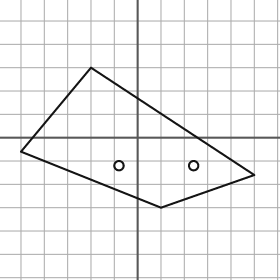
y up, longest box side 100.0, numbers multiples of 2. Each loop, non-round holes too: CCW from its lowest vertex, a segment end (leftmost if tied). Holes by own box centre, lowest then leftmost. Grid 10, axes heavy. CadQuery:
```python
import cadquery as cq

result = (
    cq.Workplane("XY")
    .moveTo(10.0, -30.0)
    .lineTo(50.0, -16.0)
    .lineTo(-20.0, 30.0)
    .lineTo(-50.0, -6.0)
    .close()
    .moveTo(-8.0, -12.0)
    .circle(2.0)
    .moveTo(24.0, -12.0)
    .circle(2.0)
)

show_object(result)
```